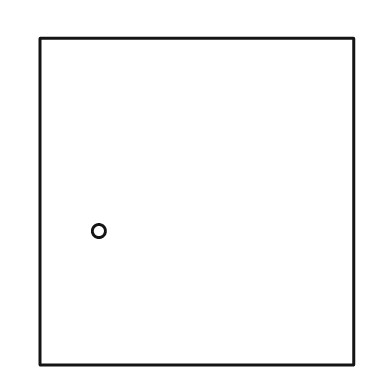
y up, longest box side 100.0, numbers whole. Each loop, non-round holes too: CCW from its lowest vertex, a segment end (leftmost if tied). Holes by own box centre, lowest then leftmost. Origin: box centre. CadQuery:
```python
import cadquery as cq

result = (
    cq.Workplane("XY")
    .moveTo(-48.0, -50.0)
    .lineTo(48.0, -50.0)
    .lineTo(48.0, 50.0)
    .lineTo(-48.0, 50.0)
    .close()
    .moveTo(-30.0, -9.0)
    .circle(2.0)
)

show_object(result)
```